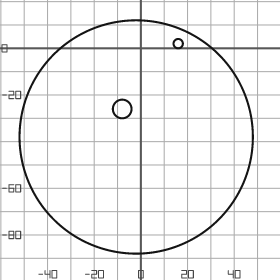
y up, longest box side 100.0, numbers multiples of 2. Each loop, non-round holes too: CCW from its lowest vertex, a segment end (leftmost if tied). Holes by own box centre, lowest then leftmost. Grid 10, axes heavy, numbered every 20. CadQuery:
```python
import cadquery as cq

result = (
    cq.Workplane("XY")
    .moveTo(-2.0, -38.0)
    .circle(50.0)
    .moveTo(-8.0, -26.0)
    .circle(4.0)
    .moveTo(16.0, 2.0)
    .circle(2.0)
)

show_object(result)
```